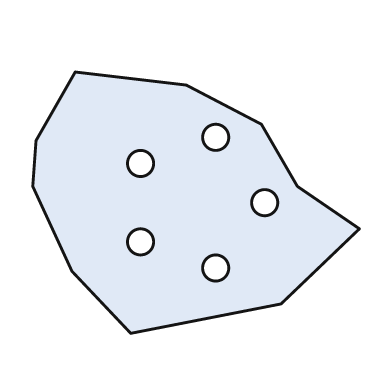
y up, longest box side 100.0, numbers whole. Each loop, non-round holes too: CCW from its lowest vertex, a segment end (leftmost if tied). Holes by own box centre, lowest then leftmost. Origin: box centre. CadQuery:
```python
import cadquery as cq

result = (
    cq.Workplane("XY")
    .moveTo(-20.0, -40.0)
    .lineTo(26.0, -31.0)
    .lineTo(50.0, -8.0)
    .lineTo(31.0, 5.0)
    .lineTo(20.0, 24.0)
    .lineTo(-3.0, 36.0)
    .lineTo(-37.0, 40.0)
    .lineTo(-49.0, 19.0)
    .lineTo(-50.0, 5.0)
    .lineTo(-38.0, -21.0)
    .close()
    .moveTo(6.0, -20.0)
    .circle(4.0)
    .moveTo(-17.0, -12.0)
    .circle(4.0)
    .moveTo(21.0, 0.0)
    .circle(4.0)
    .moveTo(-17.0, 12.0)
    .circle(4.0)
    .moveTo(6.0, 20.0)
    .circle(4.0)
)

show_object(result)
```